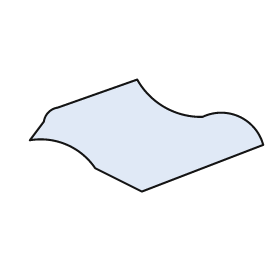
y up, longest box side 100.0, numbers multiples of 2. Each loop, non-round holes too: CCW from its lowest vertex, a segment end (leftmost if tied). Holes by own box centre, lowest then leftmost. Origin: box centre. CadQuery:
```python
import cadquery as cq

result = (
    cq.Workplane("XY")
    .moveTo(-2.0, -24.0)
    .lineTo(50.0, -4.0)
    .threePointArc((40.0, 8.0), (24.0, 8.0))
    .threePointArc((8.0, 12.0), (-4.0, 24.0))
    .lineTo(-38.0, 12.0)
    .threePointArc((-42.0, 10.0), (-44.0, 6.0))
    .lineTo(-50.0, -2.0)
    .threePointArc((-34.0, -4.0), (-22.0, -14.0))
    .close()
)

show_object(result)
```